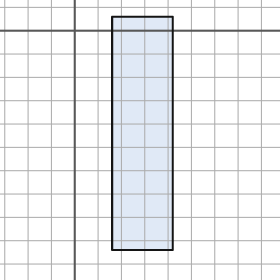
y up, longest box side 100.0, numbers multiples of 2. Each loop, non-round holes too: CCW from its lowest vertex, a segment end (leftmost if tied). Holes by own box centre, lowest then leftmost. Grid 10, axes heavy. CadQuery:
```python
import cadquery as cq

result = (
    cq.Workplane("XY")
    .moveTo(16.0, -94.0)
    .lineTo(42.0, -94.0)
    .lineTo(42.0, 6.0)
    .lineTo(16.0, 6.0)
    .close()
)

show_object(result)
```